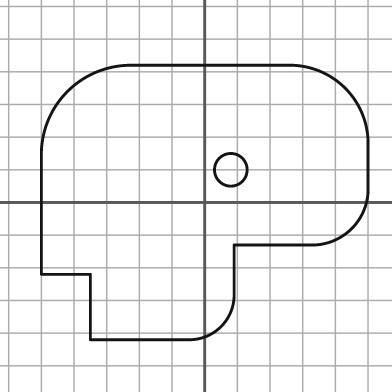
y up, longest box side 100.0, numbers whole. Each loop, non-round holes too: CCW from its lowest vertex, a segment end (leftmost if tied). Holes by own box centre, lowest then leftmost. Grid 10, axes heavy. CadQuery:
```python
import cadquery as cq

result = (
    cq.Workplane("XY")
    .moveTo(-35.0, -42.0)
    .lineTo(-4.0, -42.0)
    .threePointArc((5.0, -38.0), (9.0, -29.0))
    .lineTo(9.0, -13.0)
    .lineTo(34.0, -13.0)
    .threePointArc((45.0, -8.0), (50.0, 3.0))
    .lineTo(50.0, 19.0)
    .threePointArc((43.0, 35.0), (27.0, 42.0))
    .lineTo(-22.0, 42.0)
    .threePointArc((-42.0, 34.0), (-50.0, 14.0))
    .lineTo(-50.0, -22.0)
    .lineTo(-35.0, -22.0)
    .close()
    .moveTo(8.0, 10.0)
    .circle(5.0)
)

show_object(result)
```